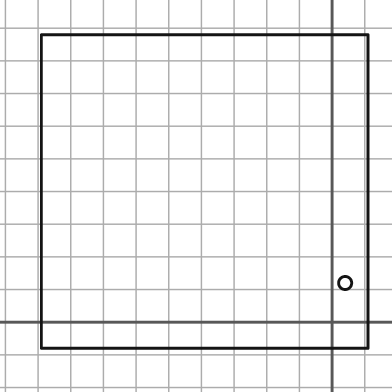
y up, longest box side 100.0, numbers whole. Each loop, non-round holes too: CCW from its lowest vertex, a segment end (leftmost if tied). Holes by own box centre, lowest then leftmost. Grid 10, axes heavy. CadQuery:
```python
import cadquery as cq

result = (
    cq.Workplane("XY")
    .moveTo(-89.0, -8.0)
    .lineTo(11.0, -8.0)
    .lineTo(11.0, 88.0)
    .lineTo(-89.0, 88.0)
    .close()
    .moveTo(4.0, 12.0)
    .circle(2.0)
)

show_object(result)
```